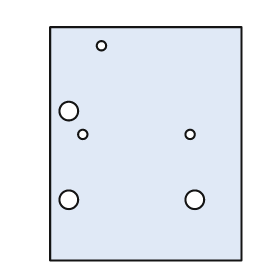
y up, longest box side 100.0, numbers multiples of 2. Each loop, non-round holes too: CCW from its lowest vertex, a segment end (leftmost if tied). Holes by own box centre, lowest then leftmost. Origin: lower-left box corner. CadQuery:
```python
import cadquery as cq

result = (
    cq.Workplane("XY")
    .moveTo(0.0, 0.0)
    .lineTo(82.0, 0.0)
    .lineTo(82.0, 100.0)
    .lineTo(0.0, 100.0)
    .close()
    .moveTo(8.0, 26.0)
    .circle(4.0)
    .moveTo(62.0, 26.0)
    .circle(4.0)
    .moveTo(14.0, 54.0)
    .circle(2.0)
    .moveTo(60.0, 54.0)
    .circle(2.0)
    .moveTo(8.0, 64.0)
    .circle(4.0)
    .moveTo(22.0, 92.0)
    .circle(2.0)
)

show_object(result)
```